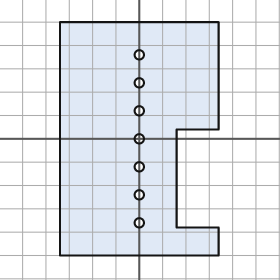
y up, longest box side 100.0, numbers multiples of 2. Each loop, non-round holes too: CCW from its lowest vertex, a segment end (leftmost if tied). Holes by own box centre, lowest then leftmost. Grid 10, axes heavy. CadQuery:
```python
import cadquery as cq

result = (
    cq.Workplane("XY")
    .moveTo(-34.0, -50.0)
    .lineTo(34.0, -50.0)
    .lineTo(34.0, -38.0)
    .lineTo(16.0, -38.0)
    .lineTo(16.0, 4.0)
    .lineTo(34.0, 4.0)
    .lineTo(34.0, 50.0)
    .lineTo(-34.0, 50.0)
    .close()
    .moveTo(0.0, -36.0)
    .circle(2.0)
    .moveTo(0.0, -24.0)
    .circle(2.0)
    .moveTo(0.0, -12.0)
    .circle(2.0)
    .moveTo(0.0, 0.0)
    .circle(2.0)
    .moveTo(0.0, 12.0)
    .circle(2.0)
    .moveTo(0.0, 24.0)
    .circle(2.0)
    .moveTo(0.0, 36.0)
    .circle(2.0)
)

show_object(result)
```